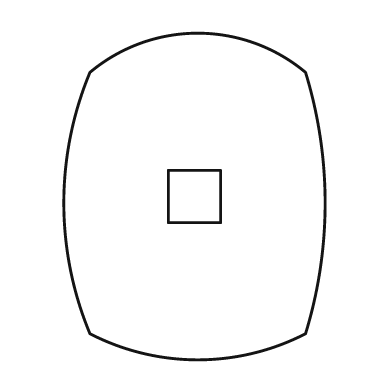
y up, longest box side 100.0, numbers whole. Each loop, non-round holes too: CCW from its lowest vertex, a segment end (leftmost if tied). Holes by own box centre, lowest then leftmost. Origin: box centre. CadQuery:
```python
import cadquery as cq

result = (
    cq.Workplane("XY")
    .moveTo(-32.0, -42.0)
    .threePointArc((1.0, -50.0), (34.0, -42.0))
    .threePointArc((40.0, -2.0), (34.0, 38.0))
    .threePointArc((1.0, 50.0), (-32.0, 38.0))
    .threePointArc((-40.0, -2.0), (-32.0, -42.0))
    .close()
    .moveTo(-8.0, -8.0)
    .lineTo(8.0, -8.0)
    .lineTo(8.0, 8.0)
    .lineTo(-8.0, 8.0)
    .close()
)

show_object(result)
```